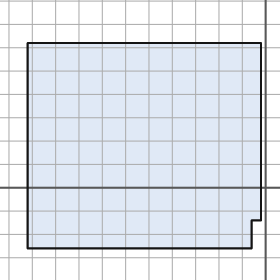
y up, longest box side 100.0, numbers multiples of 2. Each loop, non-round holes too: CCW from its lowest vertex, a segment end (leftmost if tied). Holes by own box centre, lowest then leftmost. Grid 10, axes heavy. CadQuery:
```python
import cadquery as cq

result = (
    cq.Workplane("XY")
    .moveTo(-102.0, -26.0)
    .lineTo(-6.0, -26.0)
    .lineTo(-6.0, -14.0)
    .lineTo(-2.0, -14.0)
    .lineTo(-2.0, 62.0)
    .lineTo(-102.0, 62.0)
    .close()
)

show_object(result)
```